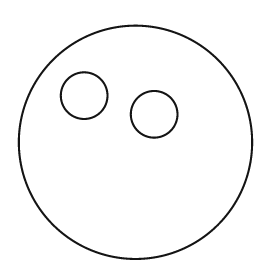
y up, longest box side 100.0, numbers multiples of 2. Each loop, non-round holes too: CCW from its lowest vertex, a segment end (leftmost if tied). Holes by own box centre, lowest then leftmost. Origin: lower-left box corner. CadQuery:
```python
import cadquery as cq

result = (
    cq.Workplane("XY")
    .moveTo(50.0, 50.0)
    .circle(50.0)
    .moveTo(58.0, 62.0)
    .circle(10.0)
    .moveTo(28.0, 70.0)
    .circle(10.0)
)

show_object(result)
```